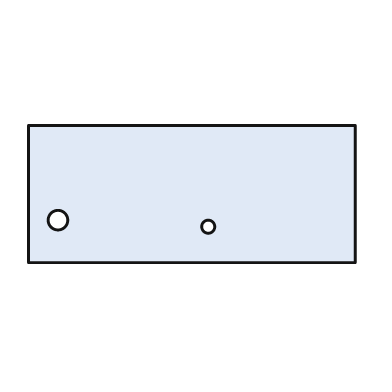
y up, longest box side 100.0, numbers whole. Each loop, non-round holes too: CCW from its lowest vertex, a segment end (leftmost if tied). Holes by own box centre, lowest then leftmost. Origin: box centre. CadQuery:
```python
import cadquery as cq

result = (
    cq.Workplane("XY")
    .moveTo(-50.0, -21.0)
    .lineTo(50.0, -21.0)
    .lineTo(50.0, 21.0)
    .lineTo(-50.0, 21.0)
    .close()
    .moveTo(5.0, -10.0)
    .circle(2.0)
    .moveTo(-41.0, -8.0)
    .circle(3.0)
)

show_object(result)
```